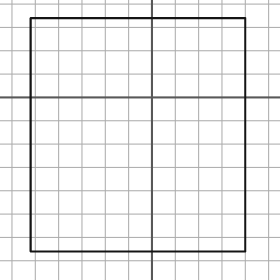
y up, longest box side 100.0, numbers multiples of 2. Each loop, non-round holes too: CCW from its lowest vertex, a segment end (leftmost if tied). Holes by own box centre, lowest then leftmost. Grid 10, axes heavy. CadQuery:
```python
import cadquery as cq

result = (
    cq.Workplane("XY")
    .moveTo(-52.0, -66.0)
    .lineTo(40.0, -66.0)
    .lineTo(40.0, 34.0)
    .lineTo(-52.0, 34.0)
    .close()
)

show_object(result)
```